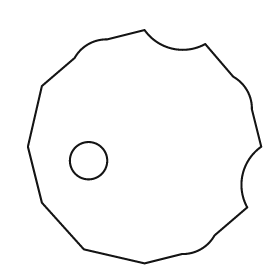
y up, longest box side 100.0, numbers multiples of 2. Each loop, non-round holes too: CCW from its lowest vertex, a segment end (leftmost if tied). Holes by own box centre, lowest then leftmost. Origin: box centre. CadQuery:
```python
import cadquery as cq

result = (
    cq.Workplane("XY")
    .moveTo(0.0, -50.0)
    .lineTo(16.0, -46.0)
    .threePointArc((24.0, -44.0), (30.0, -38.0))
    .lineTo(44.0, -26.0)
    .threePointArc((42.0, -12.0), (50.0, 0.0))
    .lineTo(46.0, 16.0)
    .threePointArc((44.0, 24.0), (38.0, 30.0))
    .lineTo(26.0, 44.0)
    .threePointArc((12.0, 42.0), (0.0, 50.0))
    .lineTo(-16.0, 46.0)
    .threePointArc((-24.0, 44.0), (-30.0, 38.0))
    .lineTo(-44.0, 26.0)
    .lineTo(-50.0, 0.0)
    .lineTo(-44.0, -24.0)
    .lineTo(-26.0, -44.0)
    .close()
    .moveTo(-24.0, -6.0)
    .circle(8.0)
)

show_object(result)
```